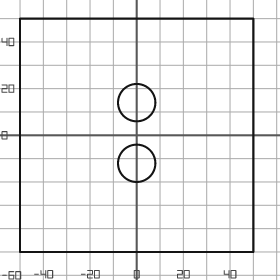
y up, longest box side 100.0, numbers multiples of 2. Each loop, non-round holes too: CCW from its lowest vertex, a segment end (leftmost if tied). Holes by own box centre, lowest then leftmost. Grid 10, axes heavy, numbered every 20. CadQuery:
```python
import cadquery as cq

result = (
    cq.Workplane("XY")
    .moveTo(-50.0, -50.0)
    .lineTo(50.0, -50.0)
    .lineTo(50.0, 50.0)
    .lineTo(-50.0, 50.0)
    .close()
    .moveTo(0.0, -12.0)
    .circle(8.0)
    .moveTo(0.0, 14.0)
    .circle(8.0)
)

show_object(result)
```